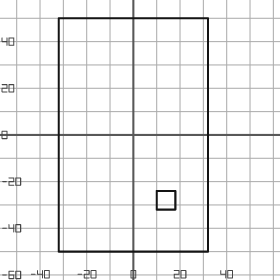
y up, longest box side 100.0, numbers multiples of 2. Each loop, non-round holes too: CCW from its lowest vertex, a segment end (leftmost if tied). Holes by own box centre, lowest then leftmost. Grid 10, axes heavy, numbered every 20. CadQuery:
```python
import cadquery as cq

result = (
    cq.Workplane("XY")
    .moveTo(-32.0, -50.0)
    .lineTo(32.0, -50.0)
    .lineTo(32.0, 50.0)
    .lineTo(-32.0, 50.0)
    .close()
    .moveTo(10.0, -32.0)
    .lineTo(18.0, -32.0)
    .lineTo(18.0, -24.0)
    .lineTo(10.0, -24.0)
    .close()
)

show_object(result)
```